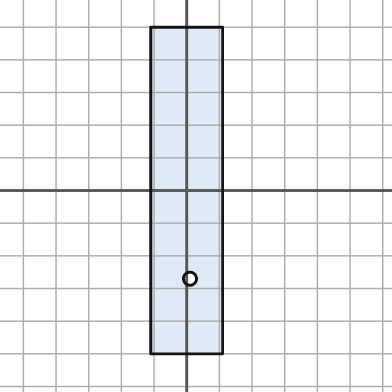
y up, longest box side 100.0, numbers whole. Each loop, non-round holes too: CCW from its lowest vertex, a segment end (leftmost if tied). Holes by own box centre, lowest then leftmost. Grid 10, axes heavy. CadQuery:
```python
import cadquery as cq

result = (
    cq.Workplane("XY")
    .moveTo(-11.0, -50.0)
    .lineTo(11.0, -50.0)
    .lineTo(11.0, 50.0)
    .lineTo(-11.0, 50.0)
    .close()
    .moveTo(1.0, -27.0)
    .circle(2.0)
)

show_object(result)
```